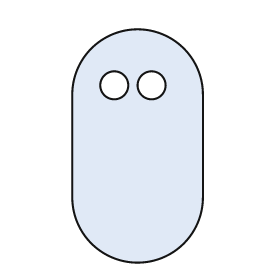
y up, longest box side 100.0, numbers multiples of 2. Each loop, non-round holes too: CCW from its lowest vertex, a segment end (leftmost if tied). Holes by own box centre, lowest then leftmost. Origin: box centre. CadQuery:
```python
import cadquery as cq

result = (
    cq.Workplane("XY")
    .moveTo(-28.0, -22.0)
    .threePointArc((0.0, -50.0), (28.0, -22.0))
    .lineTo(28.0, 22.0)
    .threePointArc((0.0, 50.0), (-28.0, 22.0))
    .close()
    .moveTo(-10.0, 26.0)
    .circle(6.0)
    .moveTo(6.0, 26.0)
    .circle(6.0)
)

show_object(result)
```